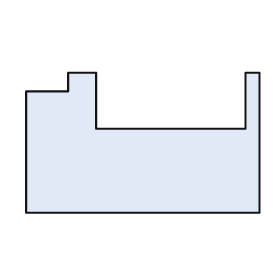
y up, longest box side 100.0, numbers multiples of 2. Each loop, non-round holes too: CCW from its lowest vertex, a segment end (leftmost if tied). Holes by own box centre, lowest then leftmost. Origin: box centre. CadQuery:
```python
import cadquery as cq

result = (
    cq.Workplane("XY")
    .moveTo(-50.0, -30.0)
    .lineTo(50.0, -30.0)
    .lineTo(50.0, 30.0)
    .lineTo(44.0, 30.0)
    .lineTo(44.0, 6.0)
    .lineTo(-20.0, 6.0)
    .lineTo(-20.0, 30.0)
    .lineTo(-32.0, 30.0)
    .lineTo(-32.0, 22.0)
    .lineTo(-50.0, 22.0)
    .close()
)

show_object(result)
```